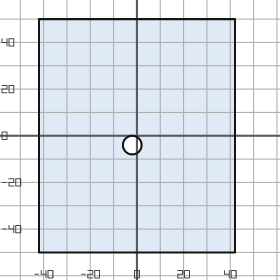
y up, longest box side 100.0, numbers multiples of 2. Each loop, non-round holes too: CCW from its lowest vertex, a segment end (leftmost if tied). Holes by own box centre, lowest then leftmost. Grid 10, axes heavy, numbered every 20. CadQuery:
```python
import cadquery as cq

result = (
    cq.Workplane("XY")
    .moveTo(-42.0, -50.0)
    .lineTo(42.0, -50.0)
    .lineTo(42.0, 50.0)
    .lineTo(-42.0, 50.0)
    .close()
    .moveTo(-2.0, -4.0)
    .circle(4.0)
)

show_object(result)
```